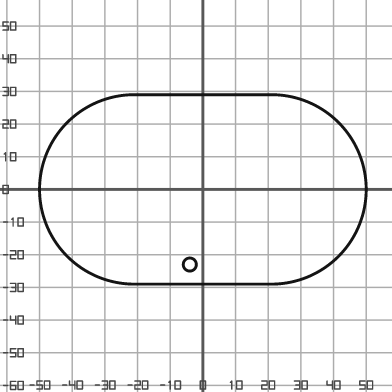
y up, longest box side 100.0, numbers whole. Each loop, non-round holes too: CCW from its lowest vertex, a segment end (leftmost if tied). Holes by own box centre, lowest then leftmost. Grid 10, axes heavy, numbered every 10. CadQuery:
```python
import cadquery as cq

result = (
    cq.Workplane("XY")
    .moveTo(-21.0, -29.0)
    .lineTo(21.0, -29.0)
    .threePointArc((50.0, 0.0), (21.0, 29.0))
    .lineTo(-21.0, 29.0)
    .threePointArc((-50.0, 0.0), (-21.0, -29.0))
    .close()
    .moveTo(-4.0, -23.0)
    .circle(2.0)
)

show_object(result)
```